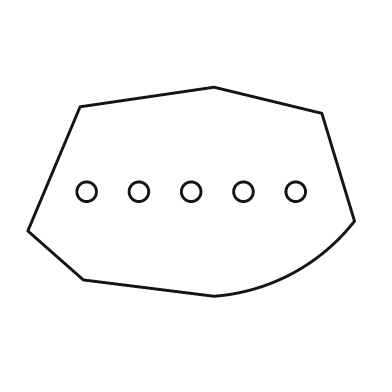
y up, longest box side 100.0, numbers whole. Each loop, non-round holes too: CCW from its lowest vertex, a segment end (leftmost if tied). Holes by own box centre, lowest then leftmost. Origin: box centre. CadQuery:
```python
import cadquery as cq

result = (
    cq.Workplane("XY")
    .moveTo(7.0, -32.0)
    .threePointArc((31.0, -25.0), (50.0, -9.0))
    .lineTo(40.0, 24.0)
    .lineTo(7.0, 32.0)
    .lineTo(-34.0, 26.0)
    .lineTo(-50.0, -12.0)
    .lineTo(-33.0, -27.0)
    .close()
    .moveTo(-32.0, 0.0)
    .circle(3.0)
    .moveTo(-16.0, 0.0)
    .circle(3.0)
    .moveTo(0.0, 0.0)
    .circle(3.0)
    .moveTo(16.0, 0.0)
    .circle(3.0)
    .moveTo(32.0, 0.0)
    .circle(3.0)
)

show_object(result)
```